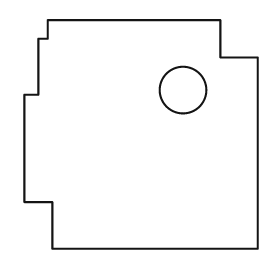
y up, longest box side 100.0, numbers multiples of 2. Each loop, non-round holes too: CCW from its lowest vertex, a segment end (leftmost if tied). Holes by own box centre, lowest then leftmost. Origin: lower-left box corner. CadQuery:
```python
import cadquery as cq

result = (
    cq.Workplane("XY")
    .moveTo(12.0, 0.0)
    .lineTo(100.0, 0.0)
    .lineTo(100.0, 82.0)
    .lineTo(84.0, 82.0)
    .lineTo(84.0, 98.0)
    .lineTo(10.0, 98.0)
    .lineTo(10.0, 90.0)
    .lineTo(6.0, 90.0)
    .lineTo(6.0, 66.0)
    .lineTo(0.0, 66.0)
    .lineTo(0.0, 20.0)
    .lineTo(12.0, 20.0)
    .close()
    .moveTo(68.0, 68.0)
    .circle(10.0)
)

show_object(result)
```